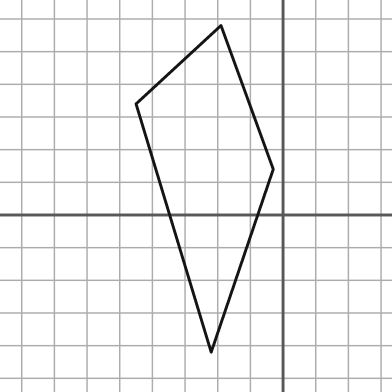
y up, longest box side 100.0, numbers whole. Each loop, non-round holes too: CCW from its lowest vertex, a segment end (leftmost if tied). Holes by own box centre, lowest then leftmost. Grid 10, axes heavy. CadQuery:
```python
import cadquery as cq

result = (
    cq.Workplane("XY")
    .moveTo(-22.0, -42.0)
    .lineTo(-3.0, 14.0)
    .lineTo(-19.0, 58.0)
    .lineTo(-45.0, 34.0)
    .close()
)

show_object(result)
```